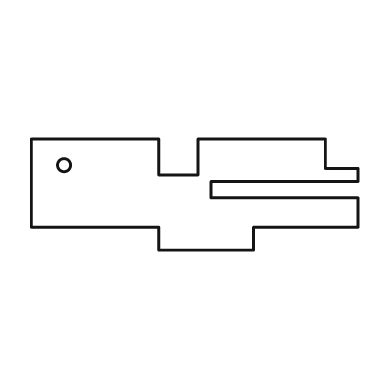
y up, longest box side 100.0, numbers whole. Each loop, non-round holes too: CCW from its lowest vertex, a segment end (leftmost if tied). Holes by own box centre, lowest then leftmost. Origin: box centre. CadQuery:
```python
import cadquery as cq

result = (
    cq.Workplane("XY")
    .moveTo(-11.0, -17.0)
    .lineTo(18.0, -17.0)
    .lineTo(18.0, -10.0)
    .lineTo(50.0, -10.0)
    .lineTo(50.0, -1.0)
    .lineTo(5.0, -1.0)
    .lineTo(5.0, 4.0)
    .lineTo(50.0, 4.0)
    .lineTo(50.0, 8.0)
    .lineTo(40.0, 8.0)
    .lineTo(40.0, 17.0)
    .lineTo(1.0, 17.0)
    .lineTo(1.0, 6.0)
    .lineTo(-11.0, 6.0)
    .lineTo(-11.0, 17.0)
    .lineTo(-50.0, 17.0)
    .lineTo(-50.0, -10.0)
    .lineTo(-11.0, -10.0)
    .close()
    .moveTo(-40.0, 9.0)
    .circle(2.0)
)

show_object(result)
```